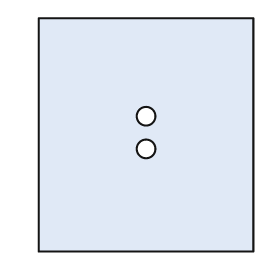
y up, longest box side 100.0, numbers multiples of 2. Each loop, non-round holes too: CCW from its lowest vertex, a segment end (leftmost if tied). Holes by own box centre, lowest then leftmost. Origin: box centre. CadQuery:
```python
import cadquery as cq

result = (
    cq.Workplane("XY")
    .moveTo(-46.0, -50.0)
    .lineTo(46.0, -50.0)
    .lineTo(46.0, 50.0)
    .lineTo(-46.0, 50.0)
    .close()
    .moveTo(0.0, -6.0)
    .circle(4.0)
    .moveTo(0.0, 8.0)
    .circle(4.0)
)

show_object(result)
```